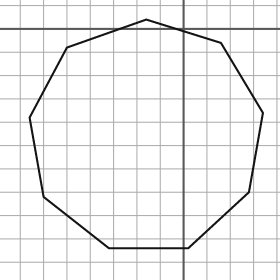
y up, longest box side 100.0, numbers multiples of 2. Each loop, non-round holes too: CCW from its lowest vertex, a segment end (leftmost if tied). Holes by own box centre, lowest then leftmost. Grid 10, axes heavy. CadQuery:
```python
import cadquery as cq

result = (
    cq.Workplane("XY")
    .moveTo(-32.0, -94.0)
    .lineTo(2.0, -94.0)
    .lineTo(28.0, -70.0)
    .lineTo(34.0, -36.0)
    .lineTo(16.0, -6.0)
    .lineTo(-16.0, 4.0)
    .lineTo(-50.0, -8.0)
    .lineTo(-66.0, -38.0)
    .lineTo(-60.0, -72.0)
    .close()
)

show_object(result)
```